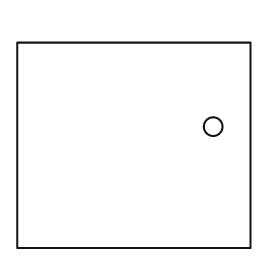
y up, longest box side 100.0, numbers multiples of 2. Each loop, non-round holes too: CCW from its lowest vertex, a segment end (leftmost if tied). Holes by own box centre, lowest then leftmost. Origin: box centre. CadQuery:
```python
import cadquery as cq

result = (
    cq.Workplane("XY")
    .moveTo(-50.0, -44.0)
    .lineTo(50.0, -44.0)
    .lineTo(50.0, 44.0)
    .lineTo(-50.0, 44.0)
    .close()
    .moveTo(34.0, 8.0)
    .circle(4.0)
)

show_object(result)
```